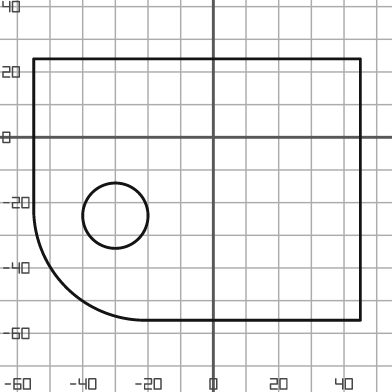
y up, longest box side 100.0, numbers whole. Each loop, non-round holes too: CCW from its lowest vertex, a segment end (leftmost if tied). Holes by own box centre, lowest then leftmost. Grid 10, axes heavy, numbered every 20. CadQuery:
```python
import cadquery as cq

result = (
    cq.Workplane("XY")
    .moveTo(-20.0, -56.0)
    .lineTo(45.0, -56.0)
    .lineTo(45.0, 24.0)
    .lineTo(-55.0, 24.0)
    .lineTo(-55.0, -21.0)
    .threePointArc((-45.0, -46.0), (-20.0, -56.0))
    .close()
    .moveTo(-30.0, -24.0)
    .circle(10.0)
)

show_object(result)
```